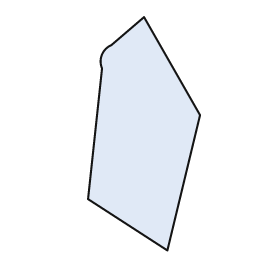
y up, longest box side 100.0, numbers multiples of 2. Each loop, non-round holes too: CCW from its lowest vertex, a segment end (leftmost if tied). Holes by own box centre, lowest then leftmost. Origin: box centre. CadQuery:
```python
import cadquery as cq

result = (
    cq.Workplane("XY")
    .moveTo(10.0, -50.0)
    .lineTo(24.0, 8.0)
    .lineTo(0.0, 50.0)
    .lineTo(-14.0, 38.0)
    .threePointArc((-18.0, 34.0), (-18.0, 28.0))
    .lineTo(-24.0, -28.0)
    .close()
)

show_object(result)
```